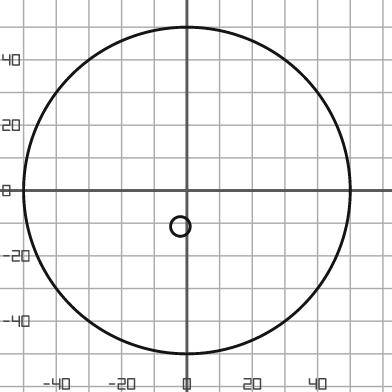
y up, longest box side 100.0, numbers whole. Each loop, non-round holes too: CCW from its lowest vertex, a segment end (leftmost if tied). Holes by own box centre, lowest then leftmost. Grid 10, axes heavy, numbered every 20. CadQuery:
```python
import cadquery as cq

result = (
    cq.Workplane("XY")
    .moveTo(0.0, 0.0)
    .circle(50.0)
    .moveTo(-2.0, -11.0)
    .circle(3.0)
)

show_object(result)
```